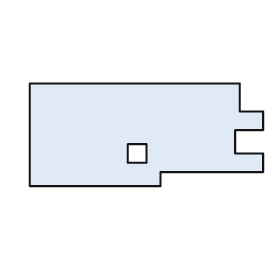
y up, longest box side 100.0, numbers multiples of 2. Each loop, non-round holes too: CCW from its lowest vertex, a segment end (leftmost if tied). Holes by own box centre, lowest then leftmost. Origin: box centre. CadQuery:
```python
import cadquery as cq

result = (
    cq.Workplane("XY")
    .moveTo(-50.0, -22.0)
    .lineTo(6.0, -22.0)
    .lineTo(6.0, -16.0)
    .lineTo(50.0, -16.0)
    .lineTo(50.0, -8.0)
    .lineTo(38.0, -8.0)
    .lineTo(38.0, 2.0)
    .lineTo(50.0, 2.0)
    .lineTo(50.0, 10.0)
    .lineTo(40.0, 10.0)
    .lineTo(40.0, 22.0)
    .lineTo(-50.0, 22.0)
    .close()
    .moveTo(-8.0, -12.0)
    .lineTo(0.0, -12.0)
    .lineTo(0.0, -4.0)
    .lineTo(-8.0, -4.0)
    .close()
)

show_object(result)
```